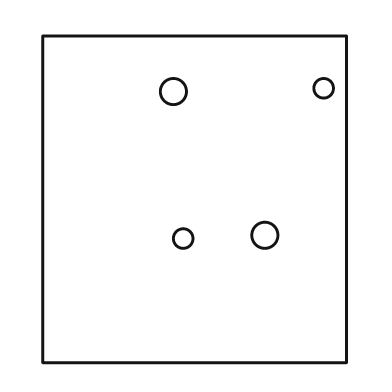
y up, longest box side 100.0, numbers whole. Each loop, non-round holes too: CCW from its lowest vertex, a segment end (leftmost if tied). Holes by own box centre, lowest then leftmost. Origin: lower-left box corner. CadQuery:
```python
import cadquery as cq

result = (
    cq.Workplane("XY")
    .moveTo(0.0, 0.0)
    .lineTo(93.0, 0.0)
    .lineTo(93.0, 100.0)
    .lineTo(0.0, 100.0)
    .close()
    .moveTo(43.0, 38.0)
    .circle(3.0)
    .moveTo(68.0, 39.0)
    .circle(4.0)
    .moveTo(40.0, 83.0)
    .circle(4.0)
    .moveTo(86.0, 84.0)
    .circle(3.0)
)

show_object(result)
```